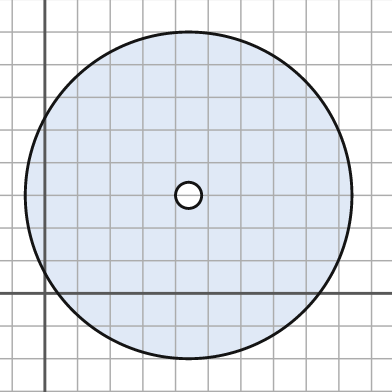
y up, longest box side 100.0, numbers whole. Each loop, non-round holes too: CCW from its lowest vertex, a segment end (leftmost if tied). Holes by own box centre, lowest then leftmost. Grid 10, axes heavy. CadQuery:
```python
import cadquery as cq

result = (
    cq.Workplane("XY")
    .moveTo(44.0, 30.0)
    .circle(50.0)
    .moveTo(44.0, 30.0)
    .circle(4.0)
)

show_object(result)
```